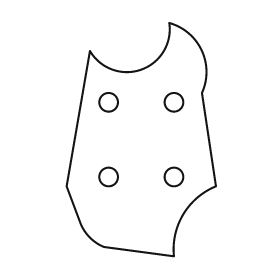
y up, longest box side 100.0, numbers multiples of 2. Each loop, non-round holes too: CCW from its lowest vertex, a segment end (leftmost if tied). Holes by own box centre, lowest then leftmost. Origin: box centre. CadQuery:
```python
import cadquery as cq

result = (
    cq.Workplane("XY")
    .moveTo(14.0, -50.0)
    .threePointArc((18.0, -32.0), (32.0, -20.0))
    .lineTo(26.0, 20.0)
    .threePointArc((26.0, 38.0), (12.0, 50.0))
    .threePointArc((0.0, 30.0), (-22.0, 38.0))
    .lineTo(-32.0, -20.0)
    .lineTo(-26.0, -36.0)
    .threePointArc((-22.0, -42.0), (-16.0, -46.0))
    .close()
    .moveTo(-14.0, -16.0)
    .circle(4.0)
    .moveTo(14.0, -16.0)
    .circle(4.0)
    .moveTo(-14.0, 16.0)
    .circle(4.0)
    .moveTo(14.0, 16.0)
    .circle(4.0)
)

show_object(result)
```